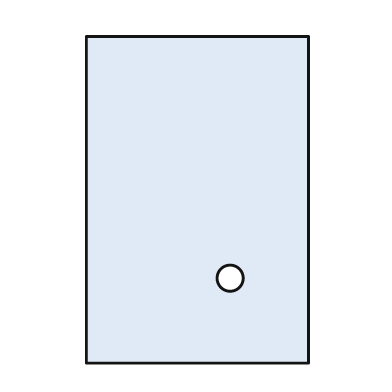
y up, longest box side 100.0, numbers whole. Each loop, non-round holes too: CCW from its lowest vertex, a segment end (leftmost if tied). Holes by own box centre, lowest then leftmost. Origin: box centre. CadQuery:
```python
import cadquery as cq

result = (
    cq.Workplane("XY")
    .moveTo(-34.0, -50.0)
    .lineTo(34.0, -50.0)
    .lineTo(34.0, 50.0)
    .lineTo(-34.0, 50.0)
    .close()
    .moveTo(10.0, -24.0)
    .circle(4.0)
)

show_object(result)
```